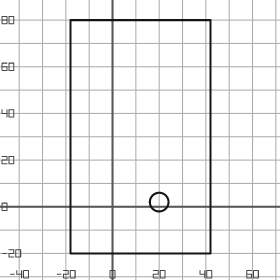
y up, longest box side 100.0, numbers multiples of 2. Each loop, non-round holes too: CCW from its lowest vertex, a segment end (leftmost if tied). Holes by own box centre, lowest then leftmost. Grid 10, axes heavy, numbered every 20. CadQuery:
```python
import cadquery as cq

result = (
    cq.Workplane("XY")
    .moveTo(-18.0, -20.0)
    .lineTo(42.0, -20.0)
    .lineTo(42.0, 80.0)
    .lineTo(-18.0, 80.0)
    .close()
    .moveTo(20.0, 2.0)
    .circle(4.0)
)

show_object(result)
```